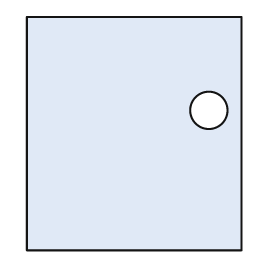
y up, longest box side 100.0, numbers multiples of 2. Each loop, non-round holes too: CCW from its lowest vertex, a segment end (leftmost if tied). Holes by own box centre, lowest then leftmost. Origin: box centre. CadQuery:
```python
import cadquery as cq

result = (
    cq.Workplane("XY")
    .moveTo(-46.0, -50.0)
    .lineTo(46.0, -50.0)
    .lineTo(46.0, 50.0)
    .lineTo(-46.0, 50.0)
    .close()
    .moveTo(32.0, 10.0)
    .circle(8.0)
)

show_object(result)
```